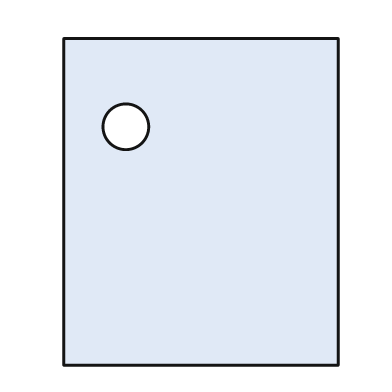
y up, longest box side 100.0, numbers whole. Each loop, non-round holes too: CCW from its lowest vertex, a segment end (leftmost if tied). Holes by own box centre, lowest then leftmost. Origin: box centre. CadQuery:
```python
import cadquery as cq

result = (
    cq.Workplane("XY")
    .moveTo(-42.0, -50.0)
    .lineTo(42.0, -50.0)
    .lineTo(42.0, 50.0)
    .lineTo(-42.0, 50.0)
    .close()
    .moveTo(-23.0, 23.0)
    .circle(7.0)
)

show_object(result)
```